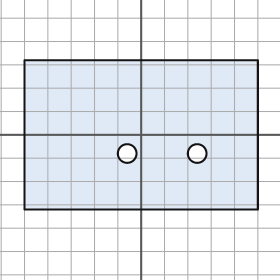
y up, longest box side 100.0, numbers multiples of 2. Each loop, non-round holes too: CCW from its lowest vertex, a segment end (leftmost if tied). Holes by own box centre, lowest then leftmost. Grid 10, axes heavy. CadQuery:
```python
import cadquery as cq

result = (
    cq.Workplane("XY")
    .moveTo(-50.0, -32.0)
    .lineTo(50.0, -32.0)
    .lineTo(50.0, 32.0)
    .lineTo(-50.0, 32.0)
    .close()
    .moveTo(-6.0, -8.0)
    .circle(4.0)
    .moveTo(24.0, -8.0)
    .circle(4.0)
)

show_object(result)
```